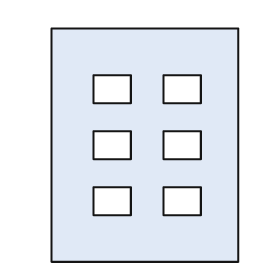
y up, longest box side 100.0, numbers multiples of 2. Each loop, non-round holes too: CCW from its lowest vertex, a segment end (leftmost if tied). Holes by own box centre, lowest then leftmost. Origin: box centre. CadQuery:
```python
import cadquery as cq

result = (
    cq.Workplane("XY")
    .moveTo(-40.0, -50.0)
    .lineTo(40.0, -50.0)
    .lineTo(40.0, 50.0)
    .lineTo(-40.0, 50.0)
    .close()
    .moveTo(-22.0, -30.0)
    .lineTo(-6.0, -30.0)
    .lineTo(-6.0, -18.0)
    .lineTo(-22.0, -18.0)
    .close()
    .moveTo(8.0, -30.0)
    .lineTo(24.0, -30.0)
    .lineTo(24.0, -18.0)
    .lineTo(8.0, -18.0)
    .close()
    .moveTo(-22.0, -6.0)
    .lineTo(-6.0, -6.0)
    .lineTo(-6.0, 6.0)
    .lineTo(-22.0, 6.0)
    .close()
    .moveTo(8.0, -6.0)
    .lineTo(24.0, -6.0)
    .lineTo(24.0, 6.0)
    .lineTo(8.0, 6.0)
    .close()
    .moveTo(-22.0, 18.0)
    .lineTo(-6.0, 18.0)
    .lineTo(-6.0, 30.0)
    .lineTo(-22.0, 30.0)
    .close()
    .moveTo(8.0, 18.0)
    .lineTo(24.0, 18.0)
    .lineTo(24.0, 30.0)
    .lineTo(8.0, 30.0)
    .close()
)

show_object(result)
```